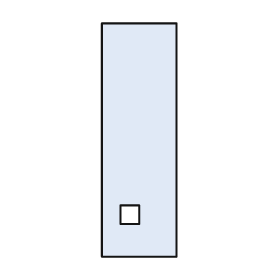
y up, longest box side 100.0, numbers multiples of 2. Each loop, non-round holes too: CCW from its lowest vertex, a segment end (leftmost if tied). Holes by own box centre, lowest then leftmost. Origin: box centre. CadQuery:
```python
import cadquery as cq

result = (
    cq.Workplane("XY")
    .moveTo(-16.0, -50.0)
    .lineTo(16.0, -50.0)
    .lineTo(16.0, 50.0)
    .lineTo(-16.0, 50.0)
    .close()
    .moveTo(-8.0, -36.0)
    .lineTo(0.0, -36.0)
    .lineTo(0.0, -28.0)
    .lineTo(-8.0, -28.0)
    .close()
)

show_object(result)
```